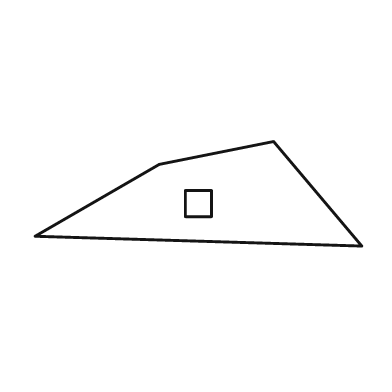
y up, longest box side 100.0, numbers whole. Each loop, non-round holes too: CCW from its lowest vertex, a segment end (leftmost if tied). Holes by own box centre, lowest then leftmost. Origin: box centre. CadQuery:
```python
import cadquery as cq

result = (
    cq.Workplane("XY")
    .moveTo(50.0, -16.0)
    .lineTo(23.0, 16.0)
    .lineTo(-12.0, 9.0)
    .lineTo(-50.0, -13.0)
    .close()
    .moveTo(-4.0, -7.0)
    .lineTo(4.0, -7.0)
    .lineTo(4.0, 1.0)
    .lineTo(-4.0, 1.0)
    .close()
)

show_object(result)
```